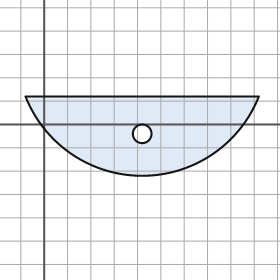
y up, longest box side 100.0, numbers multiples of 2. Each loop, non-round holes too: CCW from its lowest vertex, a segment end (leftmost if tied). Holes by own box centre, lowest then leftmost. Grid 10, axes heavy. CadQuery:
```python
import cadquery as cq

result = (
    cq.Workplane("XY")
    .moveTo(-8.0, 12.0)
    .threePointArc((42.0, -22.0), (92.0, 12.0))
    .close()
    .moveTo(42.0, -4.0)
    .circle(4.0)
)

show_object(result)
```